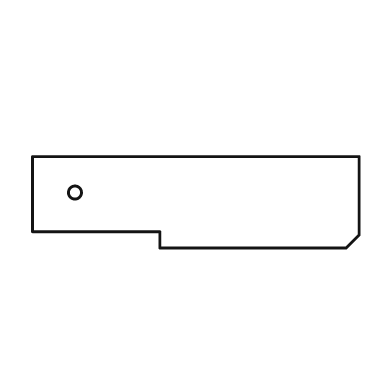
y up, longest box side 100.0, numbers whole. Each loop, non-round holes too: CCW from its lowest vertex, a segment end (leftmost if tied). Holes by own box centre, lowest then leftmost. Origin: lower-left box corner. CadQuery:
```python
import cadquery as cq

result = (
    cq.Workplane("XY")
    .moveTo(39.0, 0.0)
    .lineTo(96.0, 0.0)
    .lineTo(100.0, 4.0)
    .lineTo(100.0, 28.0)
    .lineTo(0.0, 28.0)
    .lineTo(0.0, 5.0)
    .lineTo(39.0, 5.0)
    .close()
    .moveTo(13.0, 17.0)
    .circle(2.0)
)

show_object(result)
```